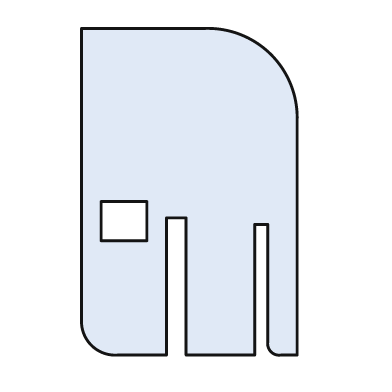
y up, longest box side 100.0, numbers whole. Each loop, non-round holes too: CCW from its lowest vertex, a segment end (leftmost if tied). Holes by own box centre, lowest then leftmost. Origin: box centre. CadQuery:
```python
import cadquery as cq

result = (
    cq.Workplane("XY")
    .moveTo(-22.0, -50.0)
    .lineTo(-7.0, -50.0)
    .lineTo(-7.0, -8.0)
    .lineTo(-1.0, -8.0)
    .lineTo(-1.0, -50.0)
    .lineTo(20.0, -50.0)
    .lineTo(20.0, -10.0)
    .lineTo(24.0, -10.0)
    .lineTo(24.0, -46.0)
    .threePointArc((25.0, -49.0), (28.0, -50.0))
    .lineTo(33.0, -50.0)
    .lineTo(33.0, 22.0)
    .threePointArc((25.0, 42.0), (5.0, 50.0))
    .lineTo(-33.0, 50.0)
    .lineTo(-33.0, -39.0)
    .threePointArc((-30.0, -47.0), (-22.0, -50.0))
    .close()
    .moveTo(-27.0, -15.0)
    .lineTo(-13.0, -15.0)
    .lineTo(-13.0, -3.0)
    .lineTo(-27.0, -3.0)
    .close()
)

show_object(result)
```